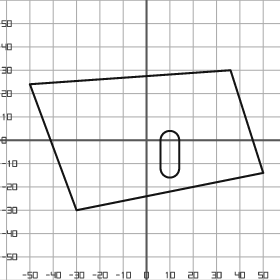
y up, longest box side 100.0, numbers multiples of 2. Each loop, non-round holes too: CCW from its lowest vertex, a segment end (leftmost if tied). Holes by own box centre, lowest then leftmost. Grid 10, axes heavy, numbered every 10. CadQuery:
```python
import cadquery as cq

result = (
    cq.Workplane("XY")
    .moveTo(-30.0, -30.0)
    .lineTo(50.0, -14.0)
    .lineTo(36.0, 30.0)
    .lineTo(-50.0, 24.0)
    .close()
    .moveTo(6.0, -12.0)
    .threePointArc((10.0, -16.0), (14.0, -12.0))
    .lineTo(14.0, 0.0)
    .threePointArc((10.0, 4.0), (6.0, 0.0))
    .close()
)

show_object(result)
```